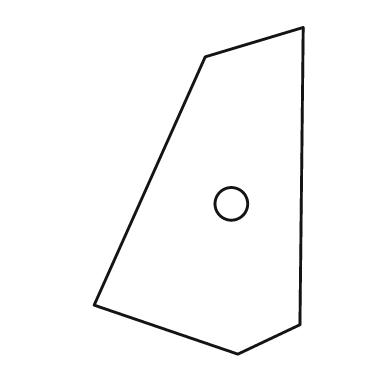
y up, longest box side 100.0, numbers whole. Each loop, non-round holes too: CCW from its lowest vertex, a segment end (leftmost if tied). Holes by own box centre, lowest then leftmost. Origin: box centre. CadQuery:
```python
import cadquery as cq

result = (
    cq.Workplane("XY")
    .moveTo(12.0, -50.0)
    .lineTo(31.0, -41.0)
    .lineTo(32.0, 50.0)
    .lineTo(2.0, 41.0)
    .lineTo(-32.0, -35.0)
    .close()
    .moveTo(10.0, -4.0)
    .circle(5.0)
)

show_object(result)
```